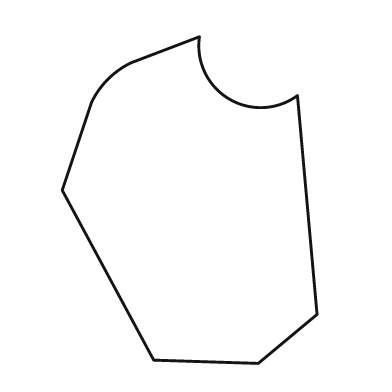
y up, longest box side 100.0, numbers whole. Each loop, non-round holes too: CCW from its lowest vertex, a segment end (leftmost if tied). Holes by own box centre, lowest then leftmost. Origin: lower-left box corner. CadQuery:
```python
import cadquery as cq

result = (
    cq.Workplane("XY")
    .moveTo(60.0, 0.0)
    .lineTo(78.0, 15.0)
    .lineTo(72.0, 82.0)
    .threePointArc((51.0, 81.0), (42.0, 100.0))
    .lineTo(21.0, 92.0)
    .threePointArc((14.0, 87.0), (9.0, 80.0))
    .lineTo(0.0, 53.0)
    .lineTo(28.0, 1.0)
    .close()
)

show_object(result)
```